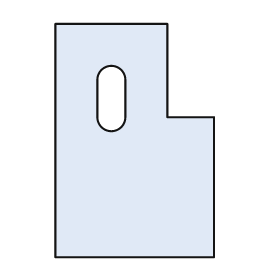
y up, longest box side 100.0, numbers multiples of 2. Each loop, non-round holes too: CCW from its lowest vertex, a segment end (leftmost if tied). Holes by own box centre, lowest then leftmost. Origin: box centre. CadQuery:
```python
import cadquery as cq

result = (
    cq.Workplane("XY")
    .moveTo(-34.0, -50.0)
    .lineTo(34.0, -50.0)
    .lineTo(34.0, 10.0)
    .lineTo(14.0, 10.0)
    .lineTo(14.0, 50.0)
    .lineTo(-34.0, 50.0)
    .close()
    .moveTo(-16.0, 10.0)
    .threePointArc((-10.0, 4.0), (-4.0, 10.0))
    .lineTo(-4.0, 26.0)
    .threePointArc((-10.0, 32.0), (-16.0, 26.0))
    .close()
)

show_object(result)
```